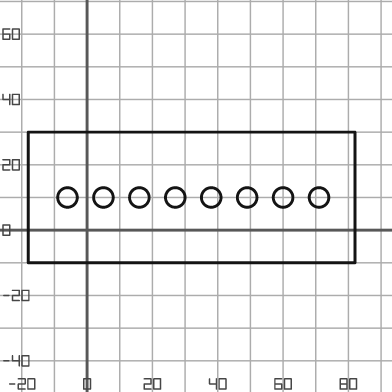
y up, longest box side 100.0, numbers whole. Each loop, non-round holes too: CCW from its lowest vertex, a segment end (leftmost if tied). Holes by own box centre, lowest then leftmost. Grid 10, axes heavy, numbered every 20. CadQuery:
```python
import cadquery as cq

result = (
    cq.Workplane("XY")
    .moveTo(-18.0, -10.0)
    .lineTo(82.0, -10.0)
    .lineTo(82.0, 30.0)
    .lineTo(-18.0, 30.0)
    .close()
    .moveTo(-6.0, 10.0)
    .circle(3.0)
    .moveTo(5.0, 10.0)
    .circle(3.0)
    .moveTo(16.0, 10.0)
    .circle(3.0)
    .moveTo(27.0, 10.0)
    .circle(3.0)
    .moveTo(38.0, 10.0)
    .circle(3.0)
    .moveTo(49.0, 10.0)
    .circle(3.0)
    .moveTo(60.0, 10.0)
    .circle(3.0)
    .moveTo(71.0, 10.0)
    .circle(3.0)
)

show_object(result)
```